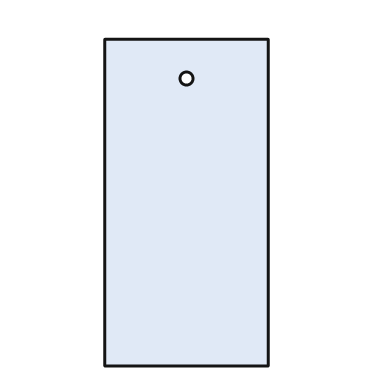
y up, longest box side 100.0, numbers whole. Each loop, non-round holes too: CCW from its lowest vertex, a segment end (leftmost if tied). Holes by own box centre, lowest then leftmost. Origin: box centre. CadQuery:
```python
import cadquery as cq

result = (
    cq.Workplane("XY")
    .moveTo(-25.0, -50.0)
    .lineTo(25.0, -50.0)
    .lineTo(25.0, 50.0)
    .lineTo(-25.0, 50.0)
    .close()
    .moveTo(0.0, 38.0)
    .circle(2.0)
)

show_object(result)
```